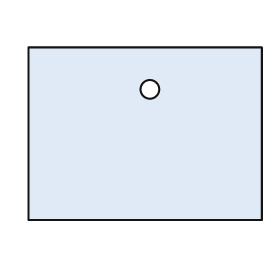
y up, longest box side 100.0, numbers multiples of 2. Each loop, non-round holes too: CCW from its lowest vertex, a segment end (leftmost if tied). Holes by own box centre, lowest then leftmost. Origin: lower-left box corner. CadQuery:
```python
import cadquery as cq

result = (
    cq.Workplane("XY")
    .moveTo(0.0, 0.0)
    .lineTo(100.0, 0.0)
    .lineTo(100.0, 74.0)
    .lineTo(0.0, 74.0)
    .close()
    .moveTo(52.0, 56.0)
    .circle(4.0)
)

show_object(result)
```